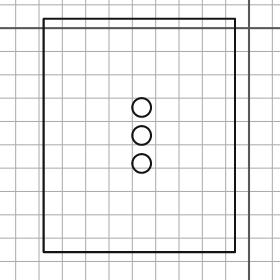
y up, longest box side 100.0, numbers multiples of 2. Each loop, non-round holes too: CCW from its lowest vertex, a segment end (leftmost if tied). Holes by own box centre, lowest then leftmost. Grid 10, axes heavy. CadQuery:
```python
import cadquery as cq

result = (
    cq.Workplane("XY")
    .moveTo(-88.0, -96.0)
    .lineTo(-6.0, -96.0)
    .lineTo(-6.0, 4.0)
    .lineTo(-88.0, 4.0)
    .close()
    .moveTo(-46.0, -58.0)
    .circle(4.0)
    .moveTo(-46.0, -46.0)
    .circle(4.0)
    .moveTo(-46.0, -34.0)
    .circle(4.0)
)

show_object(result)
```